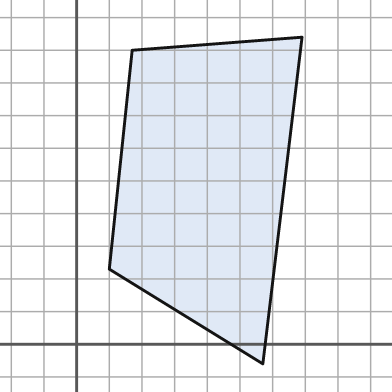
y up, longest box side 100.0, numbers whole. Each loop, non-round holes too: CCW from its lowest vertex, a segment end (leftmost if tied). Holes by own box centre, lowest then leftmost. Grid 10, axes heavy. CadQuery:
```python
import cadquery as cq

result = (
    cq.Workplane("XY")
    .moveTo(57.0, -6.0)
    .lineTo(69.0, 94.0)
    .lineTo(17.0, 90.0)
    .lineTo(10.0, 23.0)
    .close()
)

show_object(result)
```